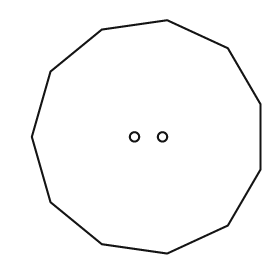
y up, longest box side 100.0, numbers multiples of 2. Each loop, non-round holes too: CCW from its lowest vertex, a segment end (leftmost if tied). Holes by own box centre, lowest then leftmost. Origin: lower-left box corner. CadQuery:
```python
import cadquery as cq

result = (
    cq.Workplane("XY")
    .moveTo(58.0, 0.0)
    .lineTo(84.0, 12.0)
    .lineTo(98.0, 36.0)
    .lineTo(98.0, 64.0)
    .lineTo(84.0, 88.0)
    .lineTo(58.0, 100.0)
    .lineTo(30.0, 96.0)
    .lineTo(8.0, 78.0)
    .lineTo(0.0, 50.0)
    .lineTo(8.0, 22.0)
    .lineTo(30.0, 4.0)
    .close()
    .moveTo(44.0, 50.0)
    .circle(2.0)
    .moveTo(56.0, 50.0)
    .circle(2.0)
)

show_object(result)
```